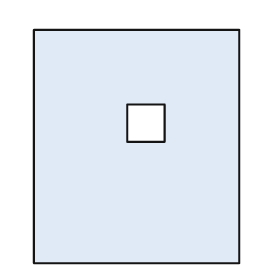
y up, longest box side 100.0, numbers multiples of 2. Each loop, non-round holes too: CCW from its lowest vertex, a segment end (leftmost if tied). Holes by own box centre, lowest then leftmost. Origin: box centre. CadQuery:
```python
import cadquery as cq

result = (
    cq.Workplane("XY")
    .moveTo(-44.0, -50.0)
    .lineTo(44.0, -50.0)
    .lineTo(44.0, 50.0)
    .lineTo(-44.0, 50.0)
    .close()
    .moveTo(-4.0, 2.0)
    .lineTo(12.0, 2.0)
    .lineTo(12.0, 18.0)
    .lineTo(-4.0, 18.0)
    .close()
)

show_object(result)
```